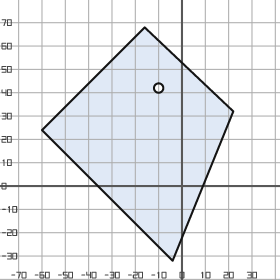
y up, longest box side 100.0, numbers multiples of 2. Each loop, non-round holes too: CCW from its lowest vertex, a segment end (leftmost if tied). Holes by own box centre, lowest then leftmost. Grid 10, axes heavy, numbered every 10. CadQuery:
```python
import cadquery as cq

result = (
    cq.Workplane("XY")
    .moveTo(-4.0, -32.0)
    .lineTo(22.0, 32.0)
    .lineTo(-16.0, 68.0)
    .lineTo(-60.0, 24.0)
    .close()
    .moveTo(-10.0, 42.0)
    .circle(2.0)
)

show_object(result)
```